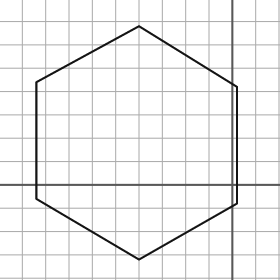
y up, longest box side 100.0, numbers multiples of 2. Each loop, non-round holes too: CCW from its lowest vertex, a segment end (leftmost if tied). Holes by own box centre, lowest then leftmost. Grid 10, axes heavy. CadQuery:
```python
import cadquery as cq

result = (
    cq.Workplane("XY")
    .moveTo(-40.0, -32.0)
    .lineTo(2.0, -8.0)
    .lineTo(2.0, 42.0)
    .lineTo(-40.0, 68.0)
    .lineTo(-84.0, 44.0)
    .lineTo(-84.0, -6.0)
    .close()
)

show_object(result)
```